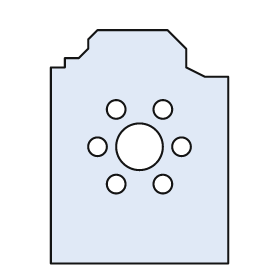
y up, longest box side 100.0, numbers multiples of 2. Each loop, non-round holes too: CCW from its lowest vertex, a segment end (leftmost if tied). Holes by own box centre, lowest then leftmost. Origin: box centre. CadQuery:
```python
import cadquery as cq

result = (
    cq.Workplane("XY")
    .moveTo(-38.0, -50.0)
    .lineTo(38.0, -50.0)
    .lineTo(38.0, 30.0)
    .lineTo(28.0, 30.0)
    .lineTo(20.0, 34.0)
    .lineTo(20.0, 42.0)
    .lineTo(12.0, 50.0)
    .lineTo(-18.0, 50.0)
    .lineTo(-22.0, 46.0)
    .lineTo(-22.0, 42.0)
    .lineTo(-26.0, 38.0)
    .lineTo(-32.0, 38.0)
    .lineTo(-32.0, 34.0)
    .lineTo(-38.0, 34.0)
    .close()
    .moveTo(-10.0, -16.0)
    .circle(4.0)
    .moveTo(10.0, -16.0)
    .circle(4.0)
    .moveTo(-18.0, 0.0)
    .circle(4.0)
    .moveTo(0.0, 0.0)
    .circle(10.0)
    .moveTo(18.0, 0.0)
    .circle(4.0)
    .moveTo(-10.0, 16.0)
    .circle(4.0)
    .moveTo(10.0, 16.0)
    .circle(4.0)
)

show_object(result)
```